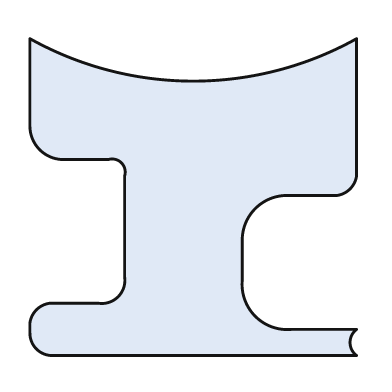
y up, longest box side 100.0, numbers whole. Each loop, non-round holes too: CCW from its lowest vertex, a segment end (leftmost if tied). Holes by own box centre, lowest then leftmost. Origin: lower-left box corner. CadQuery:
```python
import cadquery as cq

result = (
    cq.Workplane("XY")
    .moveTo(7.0, 0.0)
    .lineTo(100.0, 0.0)
    .threePointArc((98.0, 4.0), (100.0, 8.0))
    .lineTo(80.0, 8.0)
    .threePointArc((69.0, 12.0), (65.0, 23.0))
    .lineTo(65.0, 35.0)
    .threePointArc((69.0, 45.0), (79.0, 49.0))
    .lineTo(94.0, 49.0)
    .threePointArc((98.0, 51.0), (100.0, 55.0))
    .lineTo(100.0, 97.0)
    .threePointArc((50.0, 84.0), (0.0, 97.0))
    .lineTo(0.0, 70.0)
    .threePointArc((3.0, 63.0), (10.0, 60.0))
    .lineTo(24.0, 60.0)
    .threePointArc((28.0, 59.0), (29.0, 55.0))
    .lineTo(29.0, 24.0)
    .threePointArc((27.0, 18.0), (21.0, 16.0))
    .lineTo(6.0, 16.0)
    .threePointArc((2.0, 14.0), (0.0, 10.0))
    .lineTo(0.0, 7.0)
    .threePointArc((2.0, 2.0), (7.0, 0.0))
    .close()
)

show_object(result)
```